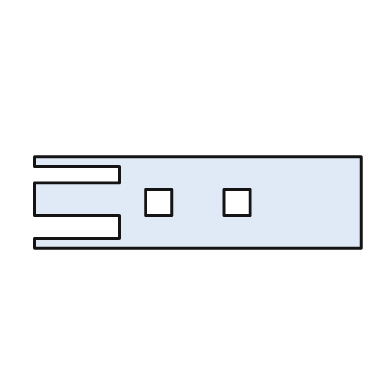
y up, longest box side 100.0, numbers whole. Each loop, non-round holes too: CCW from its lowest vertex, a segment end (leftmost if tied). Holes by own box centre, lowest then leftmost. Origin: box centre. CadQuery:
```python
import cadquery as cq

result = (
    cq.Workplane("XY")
    .moveTo(-50.0, -14.0)
    .lineTo(50.0, -14.0)
    .lineTo(50.0, 14.0)
    .lineTo(-50.0, 14.0)
    .lineTo(-50.0, 11.0)
    .lineTo(-24.0, 11.0)
    .lineTo(-24.0, 6.0)
    .lineTo(-50.0, 6.0)
    .lineTo(-50.0, -4.0)
    .lineTo(-24.0, -4.0)
    .lineTo(-24.0, -11.0)
    .lineTo(-50.0, -11.0)
    .close()
    .moveTo(-16.0, -4.0)
    .lineTo(-8.0, -4.0)
    .lineTo(-8.0, 4.0)
    .lineTo(-16.0, 4.0)
    .close()
    .moveTo(8.0, -4.0)
    .lineTo(16.0, -4.0)
    .lineTo(16.0, 4.0)
    .lineTo(8.0, 4.0)
    .close()
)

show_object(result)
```